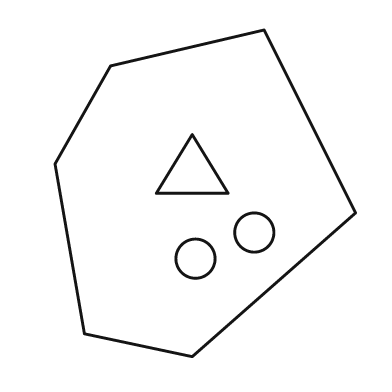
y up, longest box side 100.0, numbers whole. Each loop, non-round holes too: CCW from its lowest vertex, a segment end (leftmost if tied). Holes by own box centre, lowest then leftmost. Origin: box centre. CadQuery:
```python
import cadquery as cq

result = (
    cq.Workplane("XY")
    .moveTo(-4.0, -50.0)
    .lineTo(46.0, -6.0)
    .lineTo(18.0, 50.0)
    .lineTo(-29.0, 39.0)
    .lineTo(-46.0, 9.0)
    .lineTo(-37.0, -43.0)
    .close()
    .moveTo(-3.0, -20.0)
    .circle(6.0)
    .moveTo(15.0, -12.0)
    .circle(6.0)
    .moveTo(-15.0, 0.0)
    .lineTo(7.0, 0.0)
    .lineTo(-4.0, 18.0)
    .close()
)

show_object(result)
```